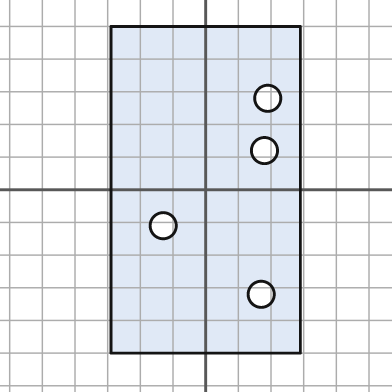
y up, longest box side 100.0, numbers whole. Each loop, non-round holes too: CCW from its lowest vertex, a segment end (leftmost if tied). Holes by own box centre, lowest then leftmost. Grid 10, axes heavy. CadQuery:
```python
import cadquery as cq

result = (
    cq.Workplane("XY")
    .moveTo(-29.0, -50.0)
    .lineTo(29.0, -50.0)
    .lineTo(29.0, 50.0)
    .lineTo(-29.0, 50.0)
    .close()
    .moveTo(17.0, -32.0)
    .circle(4.0)
    .moveTo(-13.0, -11.0)
    .circle(4.0)
    .moveTo(18.0, 12.0)
    .circle(4.0)
    .moveTo(19.0, 28.0)
    .circle(4.0)
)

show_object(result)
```